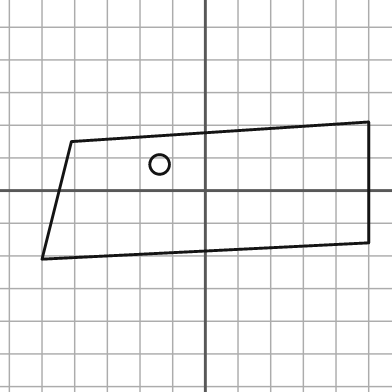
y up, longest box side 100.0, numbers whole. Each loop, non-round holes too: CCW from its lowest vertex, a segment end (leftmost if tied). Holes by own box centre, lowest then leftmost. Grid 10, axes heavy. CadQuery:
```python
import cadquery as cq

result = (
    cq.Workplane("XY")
    .moveTo(-50.0, -21.0)
    .lineTo(50.0, -16.0)
    .lineTo(50.0, 21.0)
    .lineTo(-41.0, 15.0)
    .close()
    .moveTo(-14.0, 8.0)
    .circle(3.0)
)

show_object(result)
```